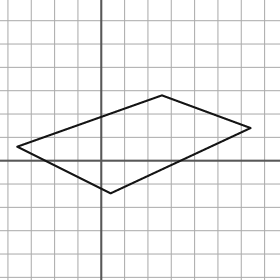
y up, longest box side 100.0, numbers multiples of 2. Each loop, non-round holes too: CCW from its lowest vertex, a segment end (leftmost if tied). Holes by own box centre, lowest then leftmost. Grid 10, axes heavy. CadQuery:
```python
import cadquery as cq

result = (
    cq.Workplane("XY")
    .moveTo(4.0, -14.0)
    .lineTo(64.0, 14.0)
    .lineTo(26.0, 28.0)
    .lineTo(-36.0, 6.0)
    .close()
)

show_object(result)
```